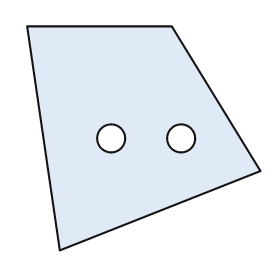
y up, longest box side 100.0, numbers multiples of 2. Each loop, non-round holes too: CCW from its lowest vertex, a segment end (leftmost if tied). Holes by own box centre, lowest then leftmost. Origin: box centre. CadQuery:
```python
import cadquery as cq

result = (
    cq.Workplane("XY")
    .moveTo(-36.0, -48.0)
    .lineTo(50.0, -14.0)
    .lineTo(12.0, 48.0)
    .lineTo(-50.0, 48.0)
    .close()
    .moveTo(-14.0, 0.0)
    .circle(6.0)
    .moveTo(16.0, 0.0)
    .circle(6.0)
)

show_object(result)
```